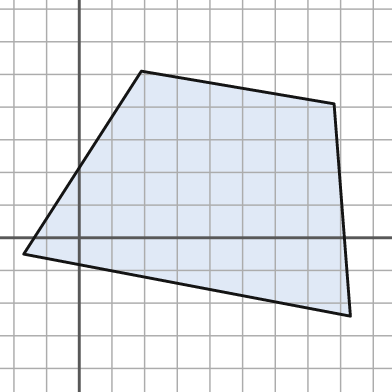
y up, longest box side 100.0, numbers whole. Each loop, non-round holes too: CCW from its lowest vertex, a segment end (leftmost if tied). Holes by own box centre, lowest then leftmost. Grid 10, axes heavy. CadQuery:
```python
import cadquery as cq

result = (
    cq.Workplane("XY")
    .moveTo(83.0, -24.0)
    .lineTo(78.0, 41.0)
    .lineTo(19.0, 51.0)
    .lineTo(-17.0, -5.0)
    .close()
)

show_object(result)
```